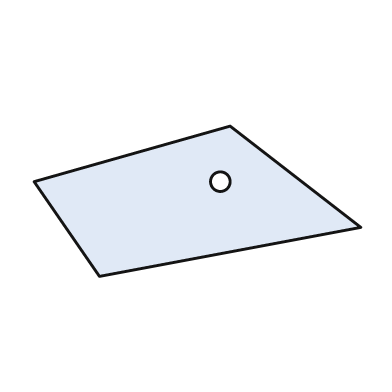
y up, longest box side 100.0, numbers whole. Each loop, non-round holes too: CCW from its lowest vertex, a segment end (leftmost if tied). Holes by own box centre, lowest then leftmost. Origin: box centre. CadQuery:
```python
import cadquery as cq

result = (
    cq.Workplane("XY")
    .moveTo(-30.0, -23.0)
    .lineTo(50.0, -8.0)
    .lineTo(10.0, 23.0)
    .lineTo(-50.0, 6.0)
    .close()
    .moveTo(7.0, 6.0)
    .circle(3.0)
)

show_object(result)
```